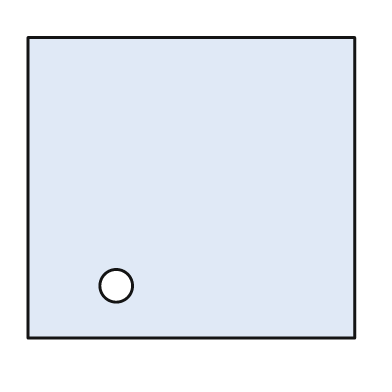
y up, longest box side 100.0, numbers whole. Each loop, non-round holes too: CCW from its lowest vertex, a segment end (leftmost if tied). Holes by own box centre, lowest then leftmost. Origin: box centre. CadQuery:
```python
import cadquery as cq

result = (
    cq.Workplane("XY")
    .moveTo(-50.0, -46.0)
    .lineTo(50.0, -46.0)
    .lineTo(50.0, 46.0)
    .lineTo(-50.0, 46.0)
    .close()
    .moveTo(-23.0, -30.0)
    .circle(5.0)
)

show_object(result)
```